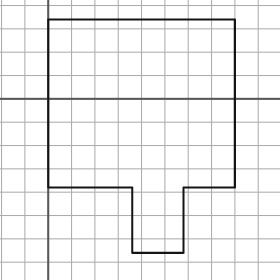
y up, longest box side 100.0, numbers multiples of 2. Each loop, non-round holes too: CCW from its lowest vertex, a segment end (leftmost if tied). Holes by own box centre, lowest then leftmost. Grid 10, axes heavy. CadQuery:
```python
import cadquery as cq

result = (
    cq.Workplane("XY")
    .moveTo(36.0, -66.0)
    .lineTo(58.0, -66.0)
    .lineTo(58.0, -38.0)
    .lineTo(80.0, -38.0)
    .lineTo(80.0, 34.0)
    .lineTo(0.0, 34.0)
    .lineTo(0.0, -38.0)
    .lineTo(36.0, -38.0)
    .close()
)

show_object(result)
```